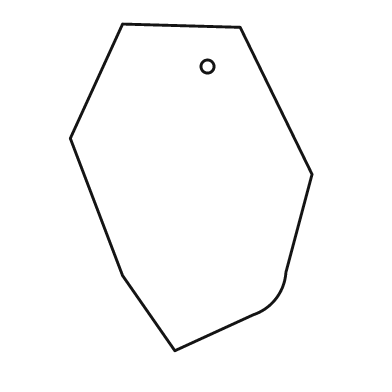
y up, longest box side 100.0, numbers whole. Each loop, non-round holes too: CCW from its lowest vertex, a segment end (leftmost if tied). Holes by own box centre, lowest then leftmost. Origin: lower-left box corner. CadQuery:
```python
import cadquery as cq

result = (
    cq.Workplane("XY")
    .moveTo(32.0, 0.0)
    .lineTo(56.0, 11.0)
    .threePointArc((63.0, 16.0), (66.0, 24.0))
    .lineTo(74.0, 54.0)
    .lineTo(52.0, 99.0)
    .lineTo(16.0, 100.0)
    .lineTo(0.0, 65.0)
    .lineTo(16.0, 23.0)
    .close()
    .moveTo(42.0, 87.0)
    .circle(2.0)
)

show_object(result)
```